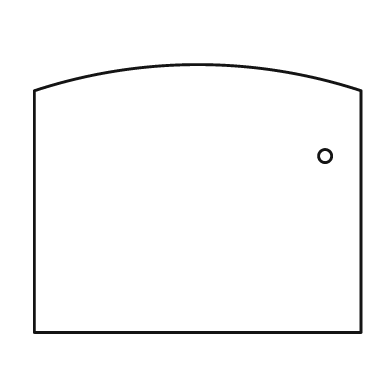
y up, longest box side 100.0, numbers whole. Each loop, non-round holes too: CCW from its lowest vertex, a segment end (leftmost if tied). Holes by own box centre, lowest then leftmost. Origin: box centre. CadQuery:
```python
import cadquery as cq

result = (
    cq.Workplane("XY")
    .moveTo(-50.0, -41.0)
    .lineTo(50.0, -41.0)
    .lineTo(50.0, 33.0)
    .threePointArc((0.0, 41.0), (-50.0, 33.0))
    .close()
    .moveTo(39.0, 13.0)
    .circle(2.0)
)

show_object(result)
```